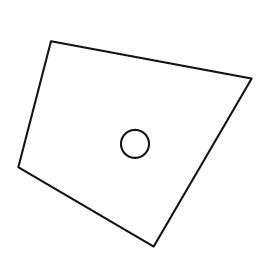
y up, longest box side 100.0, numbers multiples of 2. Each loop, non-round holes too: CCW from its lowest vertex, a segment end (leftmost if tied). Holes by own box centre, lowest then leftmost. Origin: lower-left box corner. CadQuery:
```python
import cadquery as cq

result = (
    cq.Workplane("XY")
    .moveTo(58.0, 0.0)
    .lineTo(100.0, 72.0)
    .lineTo(14.0, 88.0)
    .lineTo(0.0, 34.0)
    .close()
    .moveTo(50.0, 44.0)
    .circle(6.0)
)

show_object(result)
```